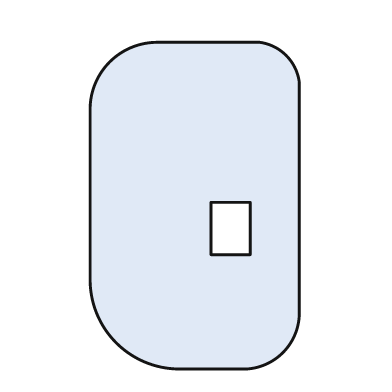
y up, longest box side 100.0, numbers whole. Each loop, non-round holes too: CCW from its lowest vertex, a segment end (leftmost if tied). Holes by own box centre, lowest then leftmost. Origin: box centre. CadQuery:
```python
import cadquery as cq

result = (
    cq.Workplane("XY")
    .moveTo(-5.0, -50.0)
    .lineTo(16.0, -50.0)
    .threePointArc((27.0, -45.0), (32.0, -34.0))
    .lineTo(32.0, 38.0)
    .threePointArc((28.0, 46.0), (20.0, 50.0))
    .lineTo(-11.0, 50.0)
    .threePointArc((-26.0, 44.0), (-32.0, 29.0))
    .lineTo(-32.0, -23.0)
    .threePointArc((-24.0, -42.0), (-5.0, -50.0))
    .close()
    .moveTo(5.0, -15.0)
    .lineTo(17.0, -15.0)
    .lineTo(17.0, 1.0)
    .lineTo(5.0, 1.0)
    .close()
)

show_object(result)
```